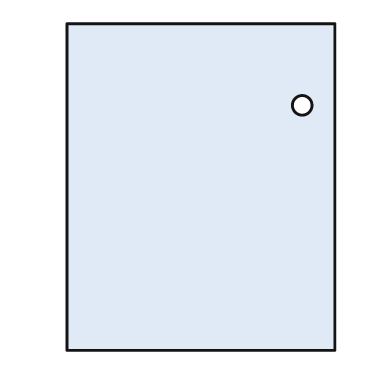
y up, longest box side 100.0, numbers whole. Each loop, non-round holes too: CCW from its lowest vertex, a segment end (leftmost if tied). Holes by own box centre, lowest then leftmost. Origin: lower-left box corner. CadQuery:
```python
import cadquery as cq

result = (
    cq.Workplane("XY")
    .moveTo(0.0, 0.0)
    .lineTo(82.0, 0.0)
    .lineTo(82.0, 100.0)
    .lineTo(0.0, 100.0)
    .close()
    .moveTo(72.0, 75.0)
    .circle(3.0)
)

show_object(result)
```